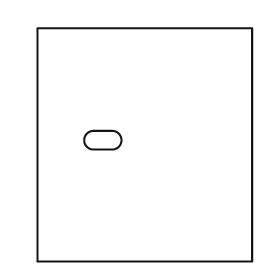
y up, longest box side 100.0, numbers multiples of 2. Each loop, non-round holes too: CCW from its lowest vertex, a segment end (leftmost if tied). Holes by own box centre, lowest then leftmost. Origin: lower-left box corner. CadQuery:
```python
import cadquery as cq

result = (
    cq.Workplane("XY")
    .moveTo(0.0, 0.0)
    .lineTo(92.0, 0.0)
    .lineTo(92.0, 100.0)
    .lineTo(0.0, 100.0)
    .close()
    .moveTo(24.0, 48.0)
    .lineTo(32.0, 48.0)
    .threePointArc((36.0, 52.0), (32.0, 56.0))
    .lineTo(24.0, 56.0)
    .threePointArc((20.0, 52.0), (24.0, 48.0))
    .close()
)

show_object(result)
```